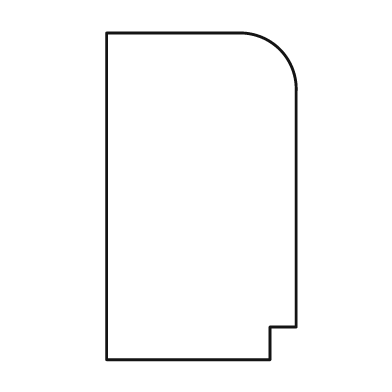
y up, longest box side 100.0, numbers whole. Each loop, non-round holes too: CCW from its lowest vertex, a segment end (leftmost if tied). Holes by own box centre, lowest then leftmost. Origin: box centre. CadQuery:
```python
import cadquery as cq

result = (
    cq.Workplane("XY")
    .moveTo(-29.0, -50.0)
    .lineTo(21.0, -50.0)
    .lineTo(21.0, -40.0)
    .lineTo(29.0, -40.0)
    .lineTo(29.0, 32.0)
    .threePointArc((24.0, 45.0), (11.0, 50.0))
    .lineTo(-29.0, 50.0)
    .close()
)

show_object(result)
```